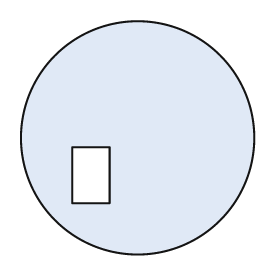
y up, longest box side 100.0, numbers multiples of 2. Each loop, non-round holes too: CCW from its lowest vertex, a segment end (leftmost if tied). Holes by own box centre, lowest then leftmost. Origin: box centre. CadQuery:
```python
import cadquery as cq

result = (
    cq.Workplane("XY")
    .moveTo(0.0, 0.0)
    .circle(50.0)
    .moveTo(-28.0, -28.0)
    .lineTo(-12.0, -28.0)
    .lineTo(-12.0, -4.0)
    .lineTo(-28.0, -4.0)
    .close()
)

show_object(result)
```